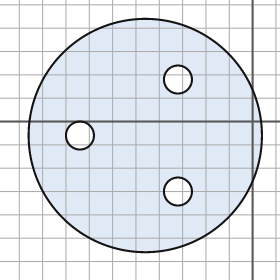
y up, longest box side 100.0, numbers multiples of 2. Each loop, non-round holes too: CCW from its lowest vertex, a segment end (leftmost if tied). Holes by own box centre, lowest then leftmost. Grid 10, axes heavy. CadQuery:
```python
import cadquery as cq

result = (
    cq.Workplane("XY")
    .moveTo(-46.0, -6.0)
    .circle(50.0)
    .moveTo(-32.0, -30.0)
    .circle(6.0)
    .moveTo(-74.0, -6.0)
    .circle(6.0)
    .moveTo(-32.0, 18.0)
    .circle(6.0)
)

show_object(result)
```